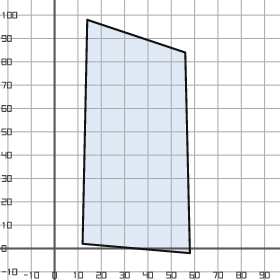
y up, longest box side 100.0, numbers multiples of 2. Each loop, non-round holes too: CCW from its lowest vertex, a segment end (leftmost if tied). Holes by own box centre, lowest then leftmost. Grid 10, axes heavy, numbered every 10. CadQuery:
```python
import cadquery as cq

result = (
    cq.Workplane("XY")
    .moveTo(58.0, -2.0)
    .lineTo(56.0, 84.0)
    .lineTo(14.0, 98.0)
    .lineTo(12.0, 2.0)
    .close()
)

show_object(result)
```